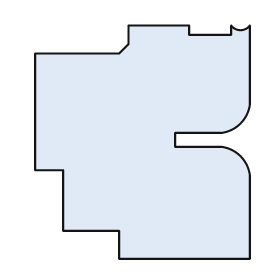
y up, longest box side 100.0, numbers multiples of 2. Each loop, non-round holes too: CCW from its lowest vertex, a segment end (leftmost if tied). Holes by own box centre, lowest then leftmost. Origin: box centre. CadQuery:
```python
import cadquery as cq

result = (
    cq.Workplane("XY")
    .moveTo(-10.0, -50.0)
    .lineTo(46.0, -50.0)
    .lineTo(46.0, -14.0)
    .threePointArc((42.0, -6.0), (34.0, -2.0))
    .lineTo(14.0, -2.0)
    .lineTo(14.0, 4.0)
    .lineTo(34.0, 4.0)
    .threePointArc((42.0, 8.0), (46.0, 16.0))
    .lineTo(46.0, 50.0)
    .threePointArc((42.0, 48.0), (38.0, 50.0))
    .lineTo(38.0, 46.0)
    .lineTo(20.0, 46.0)
    .lineTo(20.0, 50.0)
    .lineTo(-6.0, 50.0)
    .lineTo(-6.0, 42.0)
    .lineTo(-10.0, 38.0)
    .lineTo(-46.0, 38.0)
    .lineTo(-46.0, -12.0)
    .lineTo(-34.0, -12.0)
    .lineTo(-34.0, -38.0)
    .lineTo(-10.0, -38.0)
    .close()
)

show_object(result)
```